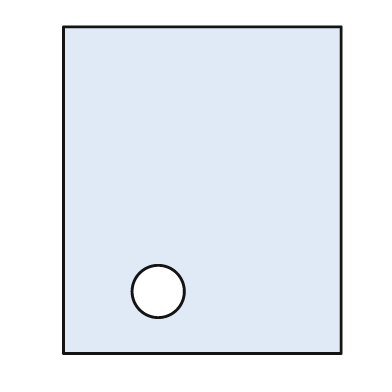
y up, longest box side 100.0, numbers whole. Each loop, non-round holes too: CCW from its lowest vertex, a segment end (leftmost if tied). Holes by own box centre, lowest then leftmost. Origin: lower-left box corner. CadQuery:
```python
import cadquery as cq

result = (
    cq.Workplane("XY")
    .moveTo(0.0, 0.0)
    .lineTo(85.0, 0.0)
    .lineTo(85.0, 100.0)
    .lineTo(0.0, 100.0)
    .close()
    .moveTo(29.0, 19.0)
    .circle(8.0)
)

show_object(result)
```